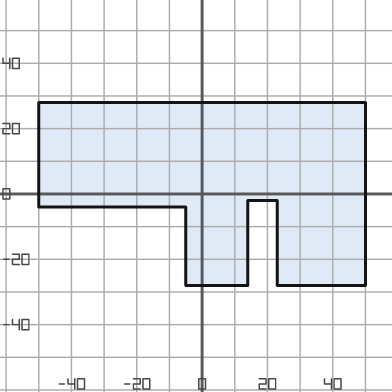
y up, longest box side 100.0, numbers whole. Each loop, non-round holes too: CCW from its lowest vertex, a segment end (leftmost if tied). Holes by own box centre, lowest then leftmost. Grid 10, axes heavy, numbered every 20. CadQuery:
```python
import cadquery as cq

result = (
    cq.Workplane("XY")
    .moveTo(-5.0, -28.0)
    .lineTo(14.0, -28.0)
    .lineTo(14.0, -2.0)
    .lineTo(23.0, -2.0)
    .lineTo(23.0, -28.0)
    .lineTo(50.0, -28.0)
    .lineTo(50.0, 28.0)
    .lineTo(-50.0, 28.0)
    .lineTo(-50.0, -4.0)
    .lineTo(-5.0, -4.0)
    .close()
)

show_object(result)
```